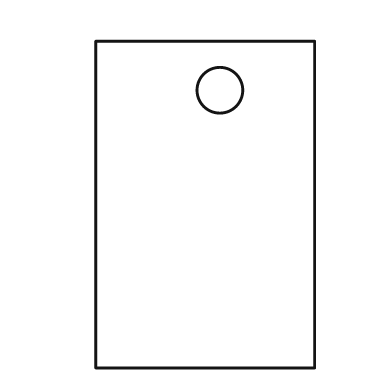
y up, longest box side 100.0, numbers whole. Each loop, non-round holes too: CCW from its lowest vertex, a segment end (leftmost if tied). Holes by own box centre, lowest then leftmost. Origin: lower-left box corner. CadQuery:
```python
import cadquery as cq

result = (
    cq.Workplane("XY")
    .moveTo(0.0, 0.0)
    .lineTo(67.0, 0.0)
    .lineTo(67.0, 100.0)
    .lineTo(0.0, 100.0)
    .close()
    .moveTo(38.0, 85.0)
    .circle(7.0)
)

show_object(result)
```